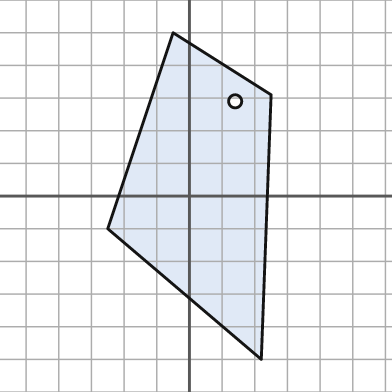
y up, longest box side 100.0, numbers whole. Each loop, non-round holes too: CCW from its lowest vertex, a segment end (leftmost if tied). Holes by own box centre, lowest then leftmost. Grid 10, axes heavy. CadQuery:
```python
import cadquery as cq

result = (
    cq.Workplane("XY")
    .moveTo(22.0, -50.0)
    .lineTo(25.0, 31.0)
    .lineTo(-5.0, 50.0)
    .lineTo(-25.0, -10.0)
    .close()
    .moveTo(14.0, 29.0)
    .circle(2.0)
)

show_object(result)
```